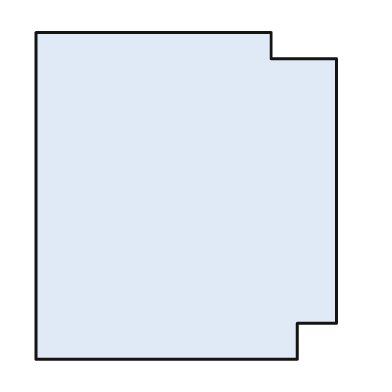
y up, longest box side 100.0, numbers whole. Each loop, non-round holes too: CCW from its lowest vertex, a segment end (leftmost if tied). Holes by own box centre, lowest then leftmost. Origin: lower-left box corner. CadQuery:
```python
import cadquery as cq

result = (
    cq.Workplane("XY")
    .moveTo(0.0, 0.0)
    .lineTo(80.0, 0.0)
    .lineTo(80.0, 11.0)
    .lineTo(92.0, 11.0)
    .lineTo(92.0, 92.0)
    .lineTo(72.0, 92.0)
    .lineTo(72.0, 100.0)
    .lineTo(0.0, 100.0)
    .close()
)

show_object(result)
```